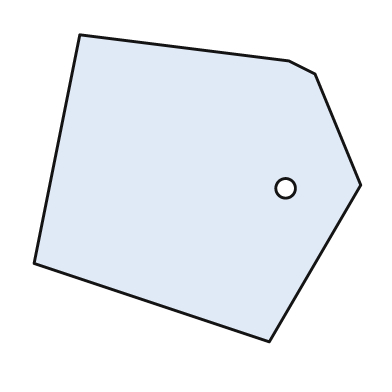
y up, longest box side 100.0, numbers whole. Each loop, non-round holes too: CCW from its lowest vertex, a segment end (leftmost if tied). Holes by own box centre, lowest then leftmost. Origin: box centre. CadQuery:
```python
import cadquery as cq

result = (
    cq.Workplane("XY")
    .moveTo(22.0, -47.0)
    .lineTo(50.0, 1.0)
    .lineTo(36.0, 35.0)
    .lineTo(28.0, 39.0)
    .lineTo(-36.0, 47.0)
    .lineTo(-50.0, -23.0)
    .close()
    .moveTo(27.0, 0.0)
    .circle(3.0)
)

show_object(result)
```